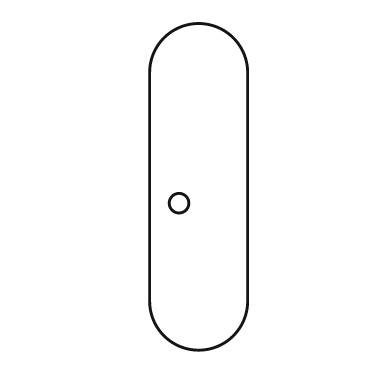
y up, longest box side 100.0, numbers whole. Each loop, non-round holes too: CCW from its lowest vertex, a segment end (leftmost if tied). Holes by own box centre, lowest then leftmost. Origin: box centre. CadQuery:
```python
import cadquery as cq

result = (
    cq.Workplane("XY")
    .moveTo(-15.0, -35.0)
    .threePointArc((0.0, -50.0), (15.0, -35.0))
    .lineTo(15.0, 35.0)
    .threePointArc((0.0, 50.0), (-15.0, 35.0))
    .close()
    .moveTo(-6.0, -5.0)
    .circle(3.0)
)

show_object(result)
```